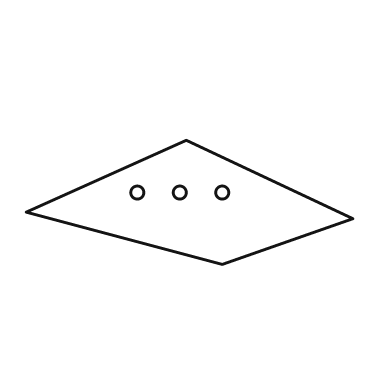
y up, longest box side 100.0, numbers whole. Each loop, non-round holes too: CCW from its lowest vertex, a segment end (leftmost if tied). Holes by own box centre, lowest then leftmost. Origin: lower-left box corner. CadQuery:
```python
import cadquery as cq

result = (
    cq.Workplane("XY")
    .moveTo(60.0, 0.0)
    .lineTo(100.0, 14.0)
    .lineTo(49.0, 38.0)
    .lineTo(0.0, 16.0)
    .close()
    .moveTo(34.0, 22.0)
    .circle(2.0)
    .moveTo(47.0, 22.0)
    .circle(2.0)
    .moveTo(60.0, 22.0)
    .circle(2.0)
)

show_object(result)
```